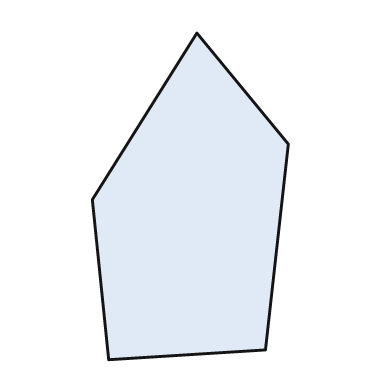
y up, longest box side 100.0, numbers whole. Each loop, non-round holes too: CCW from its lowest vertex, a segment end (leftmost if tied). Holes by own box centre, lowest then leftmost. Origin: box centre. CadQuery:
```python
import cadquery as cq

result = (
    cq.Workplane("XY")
    .moveTo(-25.0, -50.0)
    .lineTo(23.0, -47.0)
    .lineTo(30.0, 16.0)
    .lineTo(2.0, 50.0)
    .lineTo(-30.0, -1.0)
    .close()
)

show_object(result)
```